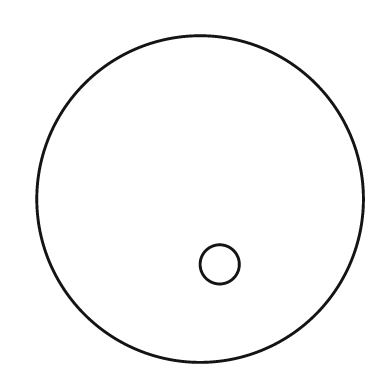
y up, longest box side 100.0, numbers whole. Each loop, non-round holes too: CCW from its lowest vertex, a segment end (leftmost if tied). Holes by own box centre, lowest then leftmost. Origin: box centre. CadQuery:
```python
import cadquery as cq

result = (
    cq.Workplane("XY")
    .moveTo(0.0, 0.0)
    .circle(50.0)
    .moveTo(6.0, -20.0)
    .circle(6.0)
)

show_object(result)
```